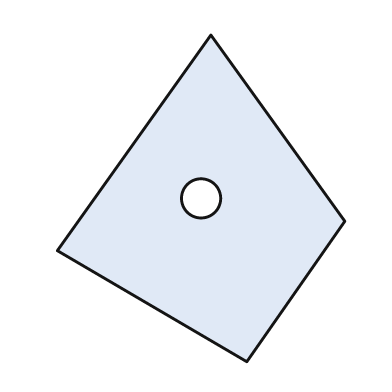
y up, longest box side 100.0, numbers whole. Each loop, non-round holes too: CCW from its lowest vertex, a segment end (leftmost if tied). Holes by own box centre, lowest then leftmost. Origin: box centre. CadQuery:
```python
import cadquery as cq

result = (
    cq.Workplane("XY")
    .moveTo(14.0, -50.0)
    .lineTo(44.0, -7.0)
    .lineTo(3.0, 50.0)
    .lineTo(-44.0, -16.0)
    .close()
    .moveTo(0.0, 0.0)
    .circle(6.0)
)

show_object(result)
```